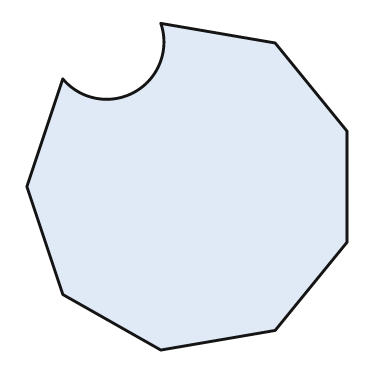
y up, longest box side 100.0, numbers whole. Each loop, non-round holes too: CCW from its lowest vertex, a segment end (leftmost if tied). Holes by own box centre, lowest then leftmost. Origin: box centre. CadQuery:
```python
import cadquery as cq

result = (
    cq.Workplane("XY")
    .moveTo(-8.0, -50.0)
    .lineTo(27.0, -44.0)
    .lineTo(49.0, -17.0)
    .lineTo(49.0, 17.0)
    .lineTo(27.0, 44.0)
    .lineTo(-8.0, 50.0)
    .threePointArc((-16.0, 29.0), (-38.0, 33.0))
    .lineTo(-49.0, 0.0)
    .lineTo(-38.0, -33.0)
    .close()
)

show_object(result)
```